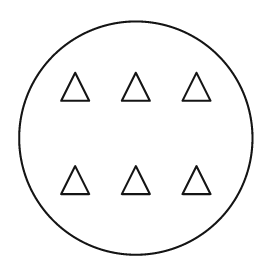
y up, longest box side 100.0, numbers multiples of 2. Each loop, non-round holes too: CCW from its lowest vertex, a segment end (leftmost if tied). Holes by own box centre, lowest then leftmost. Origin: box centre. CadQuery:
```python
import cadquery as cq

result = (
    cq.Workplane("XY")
    .moveTo(0.0, 0.0)
    .circle(50.0)
    .moveTo(-32.0, -24.0)
    .lineTo(-20.0, -24.0)
    .lineTo(-26.0, -12.0)
    .close()
    .moveTo(-6.0, -24.0)
    .lineTo(6.0, -24.0)
    .lineTo(0.0, -12.0)
    .close()
    .moveTo(20.0, -24.0)
    .lineTo(32.0, -24.0)
    .lineTo(26.0, -12.0)
    .close()
    .moveTo(-32.0, 16.0)
    .lineTo(-20.0, 16.0)
    .lineTo(-26.0, 28.0)
    .close()
    .moveTo(-6.0, 16.0)
    .lineTo(6.0, 16.0)
    .lineTo(0.0, 28.0)
    .close()
    .moveTo(20.0, 16.0)
    .lineTo(32.0, 16.0)
    .lineTo(26.0, 28.0)
    .close()
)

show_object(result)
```